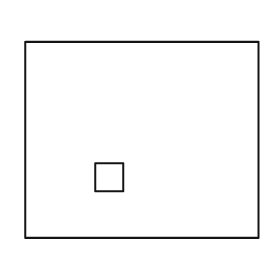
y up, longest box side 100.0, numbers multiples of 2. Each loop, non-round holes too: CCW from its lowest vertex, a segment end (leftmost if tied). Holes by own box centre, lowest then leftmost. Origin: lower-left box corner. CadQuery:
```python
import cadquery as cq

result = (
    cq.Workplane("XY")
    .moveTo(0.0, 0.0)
    .lineTo(100.0, 0.0)
    .lineTo(100.0, 84.0)
    .lineTo(0.0, 84.0)
    .close()
    .moveTo(30.0, 20.0)
    .lineTo(42.0, 20.0)
    .lineTo(42.0, 32.0)
    .lineTo(30.0, 32.0)
    .close()
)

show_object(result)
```